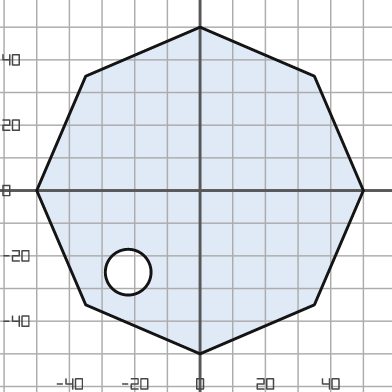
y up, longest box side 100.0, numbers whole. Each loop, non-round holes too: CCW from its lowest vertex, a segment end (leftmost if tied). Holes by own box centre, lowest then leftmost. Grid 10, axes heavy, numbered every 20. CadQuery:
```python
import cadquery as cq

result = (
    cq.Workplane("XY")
    .moveTo(0.0, -50.0)
    .lineTo(35.0, -35.0)
    .lineTo(50.0, 0.0)
    .lineTo(35.0, 35.0)
    .lineTo(0.0, 50.0)
    .lineTo(-35.0, 35.0)
    .lineTo(-50.0, 0.0)
    .lineTo(-35.0, -35.0)
    .close()
    .moveTo(-22.0, -25.0)
    .circle(7.0)
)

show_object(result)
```